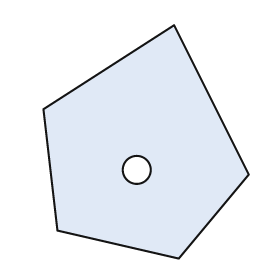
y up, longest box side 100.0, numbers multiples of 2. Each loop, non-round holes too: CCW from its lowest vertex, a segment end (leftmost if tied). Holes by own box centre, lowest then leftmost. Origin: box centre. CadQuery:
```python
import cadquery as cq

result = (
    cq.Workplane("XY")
    .moveTo(14.0, -50.0)
    .lineTo(44.0, -14.0)
    .lineTo(12.0, 50.0)
    .lineTo(-44.0, 14.0)
    .lineTo(-38.0, -38.0)
    .close()
    .moveTo(-4.0, -12.0)
    .circle(6.0)
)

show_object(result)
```